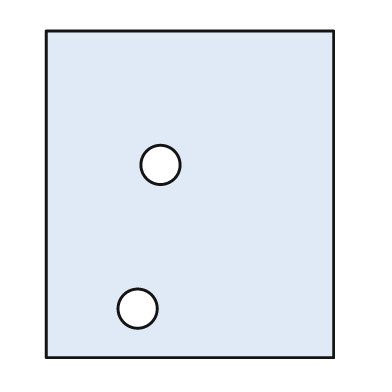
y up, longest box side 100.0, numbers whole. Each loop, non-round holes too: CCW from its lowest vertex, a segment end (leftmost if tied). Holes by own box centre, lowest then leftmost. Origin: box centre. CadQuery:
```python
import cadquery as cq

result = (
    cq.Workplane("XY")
    .moveTo(-44.0, -50.0)
    .lineTo(44.0, -50.0)
    .lineTo(44.0, 50.0)
    .lineTo(-44.0, 50.0)
    .close()
    .moveTo(-16.0, -35.0)
    .circle(6.0)
    .moveTo(-9.0, 9.0)
    .circle(6.0)
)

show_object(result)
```